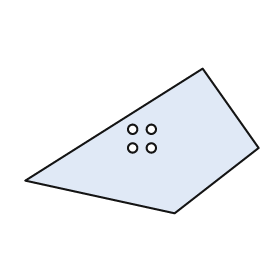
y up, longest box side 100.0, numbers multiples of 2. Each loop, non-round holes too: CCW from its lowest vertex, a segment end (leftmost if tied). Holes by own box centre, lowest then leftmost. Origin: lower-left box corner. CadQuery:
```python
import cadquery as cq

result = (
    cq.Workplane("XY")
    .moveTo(64.0, 0.0)
    .lineTo(100.0, 28.0)
    .lineTo(76.0, 62.0)
    .lineTo(0.0, 14.0)
    .close()
    .moveTo(46.0, 28.0)
    .circle(2.0)
    .moveTo(54.0, 28.0)
    .circle(2.0)
    .moveTo(46.0, 36.0)
    .circle(2.0)
    .moveTo(54.0, 36.0)
    .circle(2.0)
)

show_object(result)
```